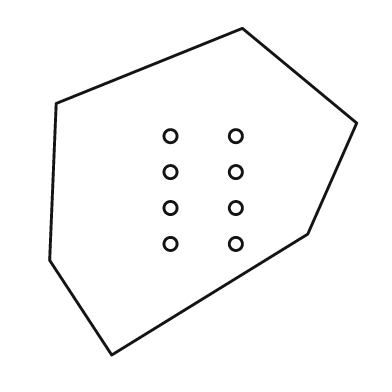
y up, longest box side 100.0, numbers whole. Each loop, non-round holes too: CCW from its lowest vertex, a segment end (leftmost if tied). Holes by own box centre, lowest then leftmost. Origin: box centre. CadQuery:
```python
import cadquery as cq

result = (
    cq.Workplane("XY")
    .moveTo(-28.0, -50.0)
    .lineTo(32.0, -13.0)
    .lineTo(47.0, 21.0)
    .lineTo(12.0, 50.0)
    .lineTo(-45.0, 27.0)
    .lineTo(-47.0, -21.0)
    .close()
    .moveTo(-10.0, -16.0)
    .circle(2.0)
    .moveTo(10.0, -16.0)
    .circle(2.0)
    .moveTo(-10.0, -5.0)
    .circle(2.0)
    .moveTo(10.0, -5.0)
    .circle(2.0)
    .moveTo(-10.0, 6.0)
    .circle(2.0)
    .moveTo(10.0, 6.0)
    .circle(2.0)
    .moveTo(-10.0, 17.0)
    .circle(2.0)
    .moveTo(10.0, 17.0)
    .circle(2.0)
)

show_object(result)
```